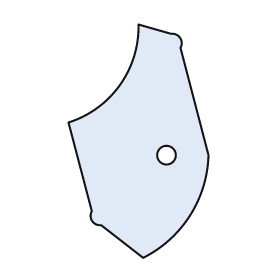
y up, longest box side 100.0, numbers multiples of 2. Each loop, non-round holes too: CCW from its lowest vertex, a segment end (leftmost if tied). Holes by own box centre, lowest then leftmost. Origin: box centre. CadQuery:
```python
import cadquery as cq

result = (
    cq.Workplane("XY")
    .moveTo(2.0, -50.0)
    .threePointArc((22.0, -32.0), (30.0, -6.0))
    .lineTo(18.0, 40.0)
    .threePointArc((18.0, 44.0), (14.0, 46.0))
    .lineTo(0.0, 50.0)
    .threePointArc((-8.0, 24.0), (-30.0, 8.0))
    .lineTo(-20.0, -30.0)
    .threePointArc((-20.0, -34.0), (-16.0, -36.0))
    .close()
    .moveTo(12.0, -6.0)
    .circle(4.0)
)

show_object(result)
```